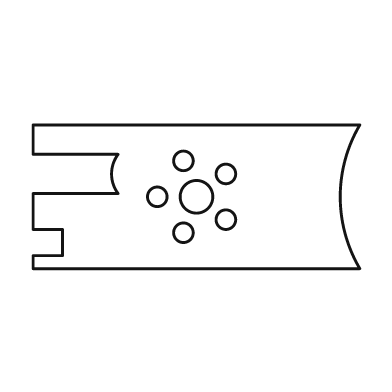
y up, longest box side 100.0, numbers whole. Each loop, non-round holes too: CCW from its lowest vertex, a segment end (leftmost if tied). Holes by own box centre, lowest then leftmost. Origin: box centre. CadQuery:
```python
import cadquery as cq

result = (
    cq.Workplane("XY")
    .moveTo(-50.0, -22.0)
    .lineTo(50.0, -22.0)
    .threePointArc((44.0, 0.0), (50.0, 22.0))
    .lineTo(-50.0, 22.0)
    .lineTo(-50.0, 13.0)
    .lineTo(-24.0, 13.0)
    .threePointArc((-26.0, 7.0), (-24.0, 1.0))
    .lineTo(-50.0, 1.0)
    .lineTo(-50.0, -10.0)
    .lineTo(-41.0, -10.0)
    .lineTo(-41.0, -18.0)
    .lineTo(-50.0, -18.0)
    .close()
    .moveTo(-4.0, -11.0)
    .circle(3.0)
    .moveTo(9.0, -7.0)
    .circle(3.0)
    .moveTo(-12.0, 0.0)
    .circle(3.0)
    .moveTo(0.0, 0.0)
    .circle(5.0)
    .moveTo(9.0, 7.0)
    .circle(3.0)
    .moveTo(-4.0, 11.0)
    .circle(3.0)
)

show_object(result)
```